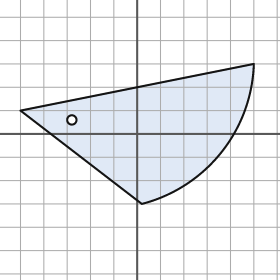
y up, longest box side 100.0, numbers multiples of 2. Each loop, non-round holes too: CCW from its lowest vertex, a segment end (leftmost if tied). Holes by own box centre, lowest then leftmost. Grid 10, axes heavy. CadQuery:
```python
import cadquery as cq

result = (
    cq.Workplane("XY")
    .moveTo(2.0, -30.0)
    .threePointArc((36.0, -8.0), (50.0, 30.0))
    .lineTo(-50.0, 10.0)
    .close()
    .moveTo(-28.0, 6.0)
    .circle(2.0)
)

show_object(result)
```